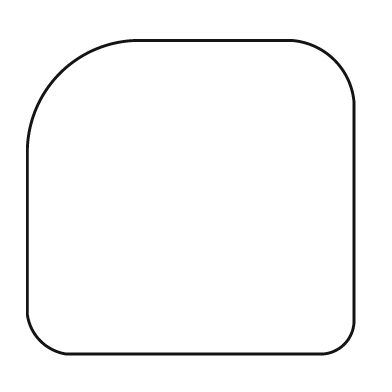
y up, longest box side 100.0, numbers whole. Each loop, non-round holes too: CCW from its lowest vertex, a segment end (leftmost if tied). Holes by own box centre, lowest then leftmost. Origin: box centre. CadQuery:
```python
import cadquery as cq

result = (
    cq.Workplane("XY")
    .moveTo(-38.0, -48.0)
    .lineTo(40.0, -48.0)
    .threePointArc((47.0, -45.0), (50.0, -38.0))
    .lineTo(50.0, 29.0)
    .threePointArc((44.0, 42.0), (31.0, 48.0))
    .lineTo(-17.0, 48.0)
    .threePointArc((-40.0, 38.0), (-50.0, 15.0))
    .lineTo(-50.0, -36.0)
    .threePointArc((-46.0, -44.0), (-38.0, -48.0))
    .close()
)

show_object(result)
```